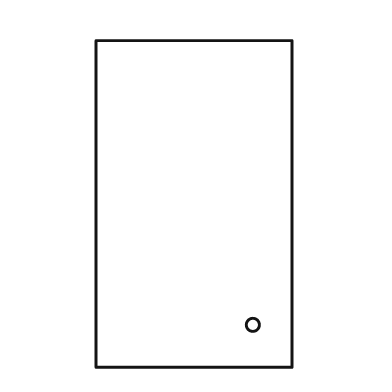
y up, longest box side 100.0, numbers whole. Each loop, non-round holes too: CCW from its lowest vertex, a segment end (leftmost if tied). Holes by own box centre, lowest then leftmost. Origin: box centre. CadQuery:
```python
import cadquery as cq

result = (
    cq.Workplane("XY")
    .moveTo(-30.0, -50.0)
    .lineTo(30.0, -50.0)
    .lineTo(30.0, 50.0)
    .lineTo(-30.0, 50.0)
    .close()
    .moveTo(18.0, -37.0)
    .circle(2.0)
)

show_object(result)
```